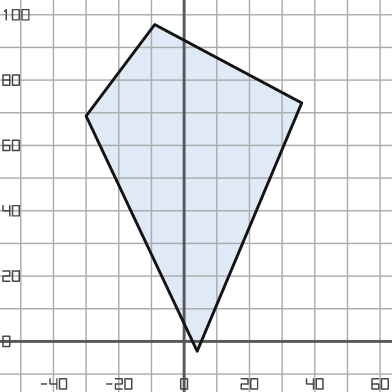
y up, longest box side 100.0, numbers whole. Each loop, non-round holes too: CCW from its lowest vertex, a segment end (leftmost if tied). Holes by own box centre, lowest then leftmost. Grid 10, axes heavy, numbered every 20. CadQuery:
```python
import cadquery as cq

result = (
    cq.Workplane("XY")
    .moveTo(4.0, -3.0)
    .lineTo(36.0, 73.0)
    .lineTo(-9.0, 97.0)
    .lineTo(-30.0, 69.0)
    .close()
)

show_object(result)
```